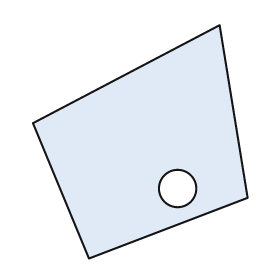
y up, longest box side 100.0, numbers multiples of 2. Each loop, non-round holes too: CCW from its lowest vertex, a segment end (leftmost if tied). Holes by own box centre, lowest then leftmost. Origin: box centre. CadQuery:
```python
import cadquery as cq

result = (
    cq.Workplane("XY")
    .moveTo(-22.0, -50.0)
    .lineTo(46.0, -24.0)
    .lineTo(34.0, 50.0)
    .lineTo(-46.0, 8.0)
    .close()
    .moveTo(16.0, -20.0)
    .circle(8.0)
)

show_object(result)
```